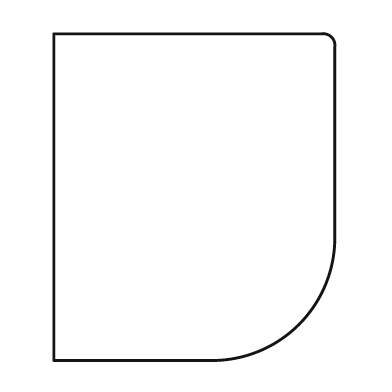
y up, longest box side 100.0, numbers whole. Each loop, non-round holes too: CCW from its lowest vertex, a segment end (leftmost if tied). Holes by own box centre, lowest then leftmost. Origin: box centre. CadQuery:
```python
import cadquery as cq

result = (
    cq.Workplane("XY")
    .moveTo(-43.0, -50.0)
    .lineTo(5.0, -50.0)
    .threePointArc((32.0, -39.0), (43.0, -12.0))
    .lineTo(43.0, 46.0)
    .threePointArc((42.0, 49.0), (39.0, 50.0))
    .lineTo(-43.0, 50.0)
    .close()
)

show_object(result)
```